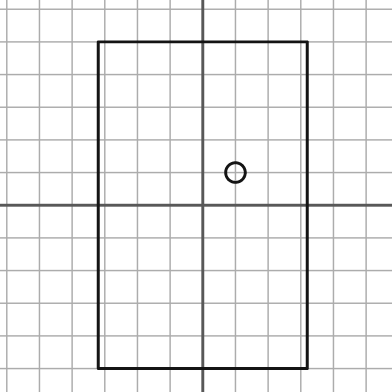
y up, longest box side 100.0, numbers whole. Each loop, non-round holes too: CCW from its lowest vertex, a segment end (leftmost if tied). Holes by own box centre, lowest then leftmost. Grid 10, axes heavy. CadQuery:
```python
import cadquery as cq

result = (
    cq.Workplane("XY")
    .moveTo(-32.0, -50.0)
    .lineTo(32.0, -50.0)
    .lineTo(32.0, 50.0)
    .lineTo(-32.0, 50.0)
    .close()
    .moveTo(10.0, 10.0)
    .circle(3.0)
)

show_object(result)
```